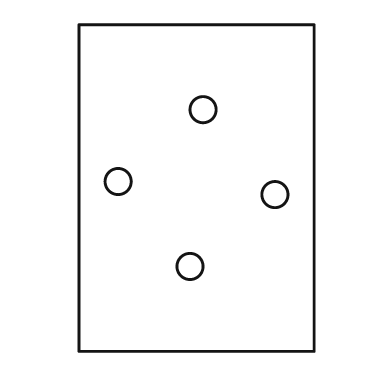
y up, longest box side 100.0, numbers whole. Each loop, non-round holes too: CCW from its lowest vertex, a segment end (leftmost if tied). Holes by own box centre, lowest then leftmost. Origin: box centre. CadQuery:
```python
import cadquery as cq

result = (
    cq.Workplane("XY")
    .moveTo(-36.0, -50.0)
    .lineTo(36.0, -50.0)
    .lineTo(36.0, 50.0)
    .lineTo(-36.0, 50.0)
    .close()
    .moveTo(-2.0, -24.0)
    .circle(4.0)
    .moveTo(24.0, -2.0)
    .circle(4.0)
    .moveTo(-24.0, 2.0)
    .circle(4.0)
    .moveTo(2.0, 24.0)
    .circle(4.0)
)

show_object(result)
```